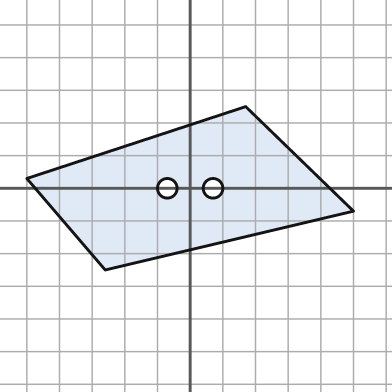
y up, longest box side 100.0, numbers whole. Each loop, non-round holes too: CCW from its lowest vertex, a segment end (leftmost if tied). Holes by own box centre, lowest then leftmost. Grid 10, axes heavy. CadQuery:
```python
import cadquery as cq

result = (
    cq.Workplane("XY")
    .moveTo(-26.0, -25.0)
    .lineTo(50.0, -7.0)
    .lineTo(17.0, 25.0)
    .lineTo(-50.0, 3.0)
    .close()
    .moveTo(-7.0, 0.0)
    .circle(3.0)
    .moveTo(7.0, 0.0)
    .circle(3.0)
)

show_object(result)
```